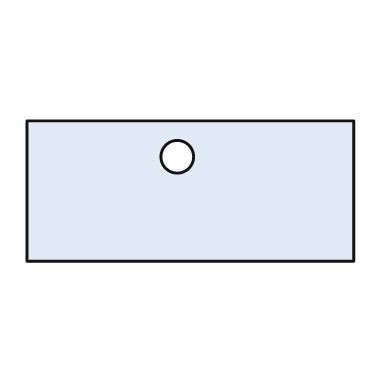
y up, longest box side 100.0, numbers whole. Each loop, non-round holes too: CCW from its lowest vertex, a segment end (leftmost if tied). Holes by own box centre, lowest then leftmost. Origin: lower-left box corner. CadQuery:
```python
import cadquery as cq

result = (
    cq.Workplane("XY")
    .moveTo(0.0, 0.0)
    .lineTo(100.0, 0.0)
    .lineTo(100.0, 43.0)
    .lineTo(0.0, 43.0)
    .close()
    .moveTo(46.0, 32.0)
    .circle(5.0)
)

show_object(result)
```